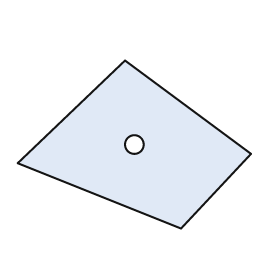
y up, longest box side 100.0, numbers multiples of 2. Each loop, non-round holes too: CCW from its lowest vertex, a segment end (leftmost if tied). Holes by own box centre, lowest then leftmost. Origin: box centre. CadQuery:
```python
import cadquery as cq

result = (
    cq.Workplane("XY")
    .moveTo(20.0, -36.0)
    .lineTo(50.0, -4.0)
    .lineTo(-4.0, 36.0)
    .lineTo(-50.0, -8.0)
    .close()
    .moveTo(0.0, 0.0)
    .circle(4.0)
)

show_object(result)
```